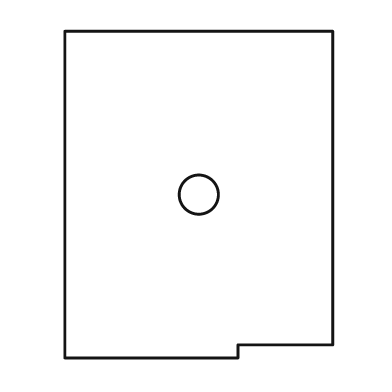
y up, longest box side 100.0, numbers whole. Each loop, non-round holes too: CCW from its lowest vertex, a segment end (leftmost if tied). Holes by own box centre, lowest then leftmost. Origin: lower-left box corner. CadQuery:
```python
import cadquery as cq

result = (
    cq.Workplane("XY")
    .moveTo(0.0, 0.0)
    .lineTo(53.0, 0.0)
    .lineTo(53.0, 4.0)
    .lineTo(82.0, 4.0)
    .lineTo(82.0, 100.0)
    .lineTo(0.0, 100.0)
    .close()
    .moveTo(41.0, 50.0)
    .circle(6.0)
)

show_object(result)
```